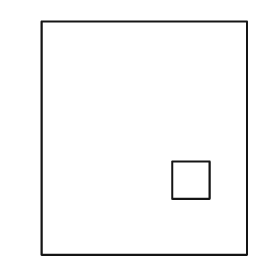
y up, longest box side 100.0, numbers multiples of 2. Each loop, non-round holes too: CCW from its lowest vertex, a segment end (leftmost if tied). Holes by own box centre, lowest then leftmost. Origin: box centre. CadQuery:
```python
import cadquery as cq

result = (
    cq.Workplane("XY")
    .moveTo(-44.0, -50.0)
    .lineTo(44.0, -50.0)
    .lineTo(44.0, 50.0)
    .lineTo(-44.0, 50.0)
    .close()
    .moveTo(12.0, -26.0)
    .lineTo(28.0, -26.0)
    .lineTo(28.0, -10.0)
    .lineTo(12.0, -10.0)
    .close()
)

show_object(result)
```